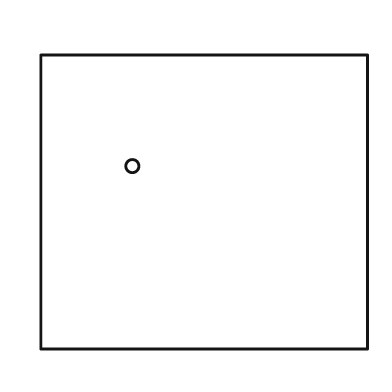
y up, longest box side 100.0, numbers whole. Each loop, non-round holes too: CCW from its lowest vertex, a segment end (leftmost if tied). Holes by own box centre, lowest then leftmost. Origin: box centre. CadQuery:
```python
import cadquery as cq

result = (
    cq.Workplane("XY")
    .moveTo(-50.0, -45.0)
    .lineTo(50.0, -45.0)
    .lineTo(50.0, 45.0)
    .lineTo(-50.0, 45.0)
    .close()
    .moveTo(-22.0, 11.0)
    .circle(2.0)
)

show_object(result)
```